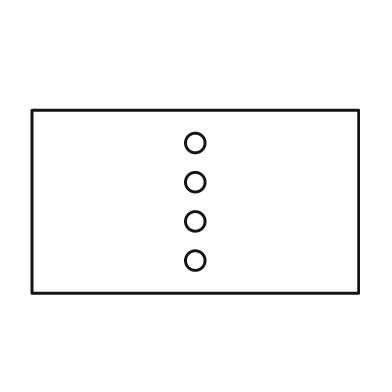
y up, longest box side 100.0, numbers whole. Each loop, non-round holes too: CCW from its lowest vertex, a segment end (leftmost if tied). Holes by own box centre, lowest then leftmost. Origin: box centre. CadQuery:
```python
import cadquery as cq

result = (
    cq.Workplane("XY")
    .moveTo(-50.0, -28.0)
    .lineTo(50.0, -28.0)
    .lineTo(50.0, 28.0)
    .lineTo(-50.0, 28.0)
    .close()
    .moveTo(0.0, -18.0)
    .circle(3.0)
    .moveTo(0.0, -6.0)
    .circle(3.0)
    .moveTo(0.0, 6.0)
    .circle(3.0)
    .moveTo(0.0, 18.0)
    .circle(3.0)
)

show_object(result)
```